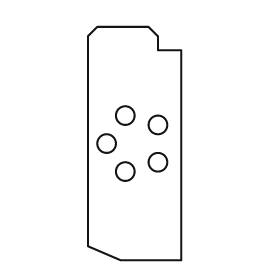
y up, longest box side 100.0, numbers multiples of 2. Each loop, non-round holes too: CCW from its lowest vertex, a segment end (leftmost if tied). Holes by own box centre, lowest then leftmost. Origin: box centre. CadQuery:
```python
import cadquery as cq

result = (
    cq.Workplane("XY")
    .moveTo(-6.0, -50.0)
    .lineTo(20.0, -50.0)
    .lineTo(20.0, 40.0)
    .lineTo(10.0, 40.0)
    .lineTo(10.0, 46.0)
    .lineTo(6.0, 50.0)
    .lineTo(-16.0, 50.0)
    .lineTo(-20.0, 46.0)
    .lineTo(-20.0, -44.0)
    .close()
    .moveTo(-4.0, -12.0)
    .circle(4.0)
    .moveTo(10.0, -8.0)
    .circle(4.0)
    .moveTo(-12.0, 0.0)
    .circle(4.0)
    .moveTo(10.0, 8.0)
    .circle(4.0)
    .moveTo(-4.0, 12.0)
    .circle(4.0)
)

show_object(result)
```